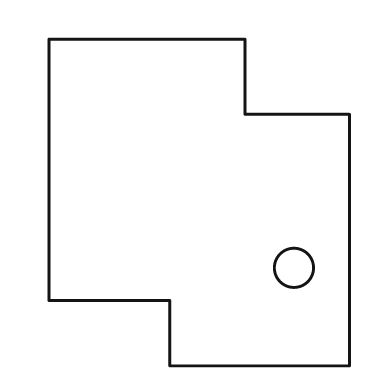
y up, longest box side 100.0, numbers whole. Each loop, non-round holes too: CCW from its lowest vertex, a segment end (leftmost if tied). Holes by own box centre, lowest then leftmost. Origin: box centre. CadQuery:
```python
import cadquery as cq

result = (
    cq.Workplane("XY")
    .moveTo(-9.0, -50.0)
    .lineTo(46.0, -50.0)
    .lineTo(46.0, 27.0)
    .lineTo(14.0, 27.0)
    .lineTo(14.0, 50.0)
    .lineTo(-46.0, 50.0)
    .lineTo(-46.0, -30.0)
    .lineTo(-9.0, -30.0)
    .close()
    .moveTo(29.0, -20.0)
    .circle(6.0)
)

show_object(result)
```